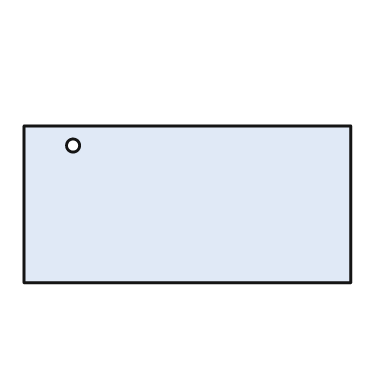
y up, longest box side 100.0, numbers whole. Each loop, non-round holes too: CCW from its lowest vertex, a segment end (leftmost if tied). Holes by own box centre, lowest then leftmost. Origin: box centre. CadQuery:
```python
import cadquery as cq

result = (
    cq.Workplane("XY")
    .moveTo(-50.0, -24.0)
    .lineTo(50.0, -24.0)
    .lineTo(50.0, 24.0)
    .lineTo(-50.0, 24.0)
    .close()
    .moveTo(-35.0, 18.0)
    .circle(2.0)
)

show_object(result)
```